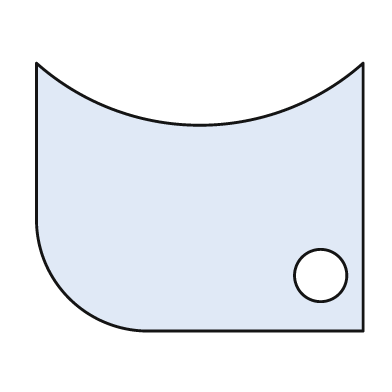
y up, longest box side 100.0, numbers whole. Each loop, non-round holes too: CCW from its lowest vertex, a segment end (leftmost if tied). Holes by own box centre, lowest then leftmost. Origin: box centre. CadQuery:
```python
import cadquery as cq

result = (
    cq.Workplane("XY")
    .moveTo(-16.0, -41.0)
    .lineTo(50.0, -41.0)
    .lineTo(50.0, 41.0)
    .threePointArc((0.0, 22.0), (-50.0, 41.0))
    .lineTo(-50.0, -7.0)
    .threePointArc((-40.0, -31.0), (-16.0, -41.0))
    .close()
    .moveTo(37.0, -24.0)
    .circle(8.0)
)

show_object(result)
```